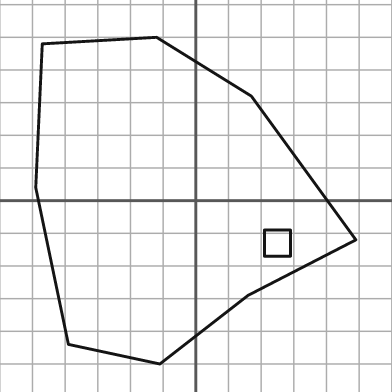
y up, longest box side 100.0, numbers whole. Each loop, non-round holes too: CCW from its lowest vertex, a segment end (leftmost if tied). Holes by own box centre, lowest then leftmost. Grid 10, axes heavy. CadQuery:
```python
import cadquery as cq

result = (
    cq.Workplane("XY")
    .moveTo(-11.0, -50.0)
    .lineTo(16.0, -29.0)
    .lineTo(49.0, -12.0)
    .lineTo(17.0, 32.0)
    .lineTo(-12.0, 50.0)
    .lineTo(-47.0, 48.0)
    .lineTo(-49.0, 4.0)
    .lineTo(-39.0, -44.0)
    .close()
    .moveTo(21.0, -17.0)
    .lineTo(29.0, -17.0)
    .lineTo(29.0, -9.0)
    .lineTo(21.0, -9.0)
    .close()
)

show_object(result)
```